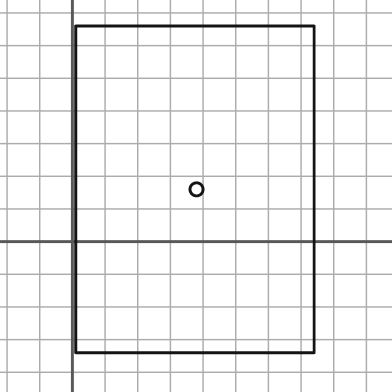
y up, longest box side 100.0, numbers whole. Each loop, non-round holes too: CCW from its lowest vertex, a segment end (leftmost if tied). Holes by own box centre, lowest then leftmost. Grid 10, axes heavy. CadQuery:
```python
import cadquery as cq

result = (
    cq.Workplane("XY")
    .moveTo(1.0, -34.0)
    .lineTo(74.0, -34.0)
    .lineTo(74.0, 66.0)
    .lineTo(1.0, 66.0)
    .close()
    .moveTo(38.0, 16.0)
    .circle(2.0)
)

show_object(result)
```